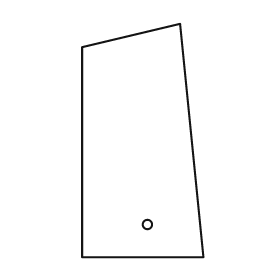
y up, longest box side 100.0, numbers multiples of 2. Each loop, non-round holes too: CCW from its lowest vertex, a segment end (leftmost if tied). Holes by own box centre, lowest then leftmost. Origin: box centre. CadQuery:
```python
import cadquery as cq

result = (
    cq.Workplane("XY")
    .moveTo(-26.0, -50.0)
    .lineTo(26.0, -50.0)
    .lineTo(16.0, 50.0)
    .lineTo(-26.0, 40.0)
    .close()
    .moveTo(2.0, -36.0)
    .circle(2.0)
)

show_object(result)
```